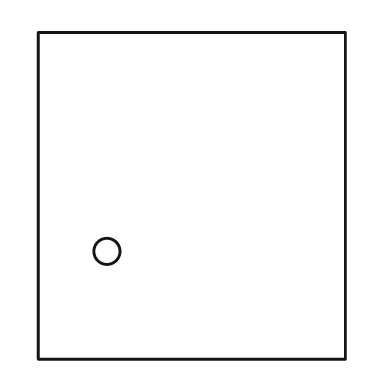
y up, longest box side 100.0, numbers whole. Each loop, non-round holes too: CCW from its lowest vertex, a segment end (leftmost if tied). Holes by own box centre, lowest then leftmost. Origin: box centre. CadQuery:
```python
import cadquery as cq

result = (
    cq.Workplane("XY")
    .moveTo(-47.0, -50.0)
    .lineTo(47.0, -50.0)
    .lineTo(47.0, 50.0)
    .lineTo(-47.0, 50.0)
    .close()
    .moveTo(-26.0, -17.0)
    .circle(4.0)
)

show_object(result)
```